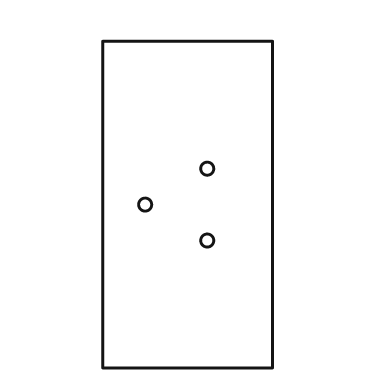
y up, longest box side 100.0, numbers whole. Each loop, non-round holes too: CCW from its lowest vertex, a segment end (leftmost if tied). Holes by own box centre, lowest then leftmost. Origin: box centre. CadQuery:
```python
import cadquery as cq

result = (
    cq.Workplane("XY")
    .moveTo(-26.0, -50.0)
    .lineTo(26.0, -50.0)
    .lineTo(26.0, 50.0)
    .lineTo(-26.0, 50.0)
    .close()
    .moveTo(6.0, -11.0)
    .circle(2.0)
    .moveTo(-13.0, 0.0)
    .circle(2.0)
    .moveTo(6.0, 11.0)
    .circle(2.0)
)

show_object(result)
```